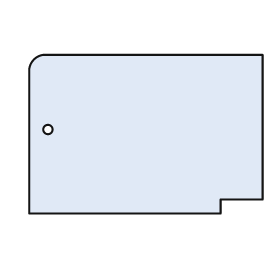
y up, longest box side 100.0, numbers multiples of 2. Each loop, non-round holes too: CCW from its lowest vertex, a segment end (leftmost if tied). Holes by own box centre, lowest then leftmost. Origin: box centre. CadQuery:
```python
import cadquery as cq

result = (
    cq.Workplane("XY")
    .moveTo(-50.0, -34.0)
    .lineTo(32.0, -34.0)
    .lineTo(32.0, -28.0)
    .lineTo(50.0, -28.0)
    .lineTo(50.0, 34.0)
    .lineTo(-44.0, 34.0)
    .threePointArc((-48.0, 32.0), (-50.0, 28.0))
    .close()
    .moveTo(-42.0, 2.0)
    .circle(2.0)
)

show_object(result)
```